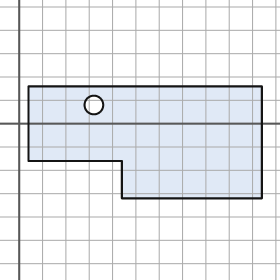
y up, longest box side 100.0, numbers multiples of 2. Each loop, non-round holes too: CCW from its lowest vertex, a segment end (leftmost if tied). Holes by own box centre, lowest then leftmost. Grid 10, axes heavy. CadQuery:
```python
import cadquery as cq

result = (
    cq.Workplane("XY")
    .moveTo(44.0, -32.0)
    .lineTo(104.0, -32.0)
    .lineTo(104.0, 16.0)
    .lineTo(4.0, 16.0)
    .lineTo(4.0, -16.0)
    .lineTo(44.0, -16.0)
    .close()
    .moveTo(32.0, 8.0)
    .circle(4.0)
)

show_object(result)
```